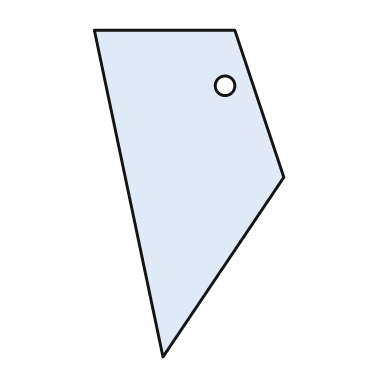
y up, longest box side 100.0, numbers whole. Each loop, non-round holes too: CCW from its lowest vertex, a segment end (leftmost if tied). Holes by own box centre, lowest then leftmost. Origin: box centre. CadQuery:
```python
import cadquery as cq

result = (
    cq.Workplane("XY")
    .moveTo(-8.0, -50.0)
    .lineTo(29.0, 5.0)
    .lineTo(14.0, 50.0)
    .lineTo(-29.0, 50.0)
    .close()
    .moveTo(11.0, 33.0)
    .circle(3.0)
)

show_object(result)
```